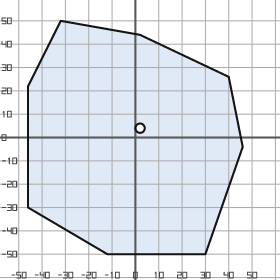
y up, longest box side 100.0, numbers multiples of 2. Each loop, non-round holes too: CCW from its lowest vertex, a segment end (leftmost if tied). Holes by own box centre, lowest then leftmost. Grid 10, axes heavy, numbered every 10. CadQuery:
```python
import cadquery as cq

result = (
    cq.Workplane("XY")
    .moveTo(-12.0, -50.0)
    .lineTo(30.0, -50.0)
    .lineTo(46.0, -4.0)
    .lineTo(40.0, 26.0)
    .lineTo(2.0, 44.0)
    .lineTo(-32.0, 50.0)
    .lineTo(-46.0, 22.0)
    .lineTo(-46.0, -30.0)
    .close()
    .moveTo(2.0, 4.0)
    .circle(2.0)
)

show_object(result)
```